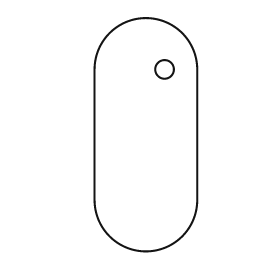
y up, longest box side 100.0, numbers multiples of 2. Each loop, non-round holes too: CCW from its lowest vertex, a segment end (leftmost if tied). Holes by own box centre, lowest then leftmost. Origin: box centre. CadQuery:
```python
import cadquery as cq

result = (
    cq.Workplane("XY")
    .moveTo(-22.0, -28.0)
    .threePointArc((0.0, -50.0), (22.0, -28.0))
    .lineTo(22.0, 28.0)
    .threePointArc((0.0, 50.0), (-22.0, 28.0))
    .close()
    .moveTo(8.0, 28.0)
    .circle(4.0)
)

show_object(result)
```